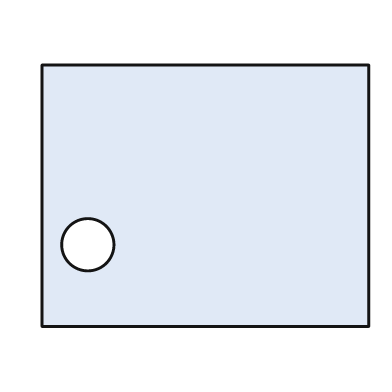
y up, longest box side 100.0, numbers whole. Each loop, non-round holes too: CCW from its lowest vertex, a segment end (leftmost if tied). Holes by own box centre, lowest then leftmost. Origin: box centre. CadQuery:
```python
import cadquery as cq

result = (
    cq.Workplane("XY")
    .moveTo(-50.0, -40.0)
    .lineTo(50.0, -40.0)
    .lineTo(50.0, 40.0)
    .lineTo(-50.0, 40.0)
    .close()
    .moveTo(-36.0, -15.0)
    .circle(8.0)
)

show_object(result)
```